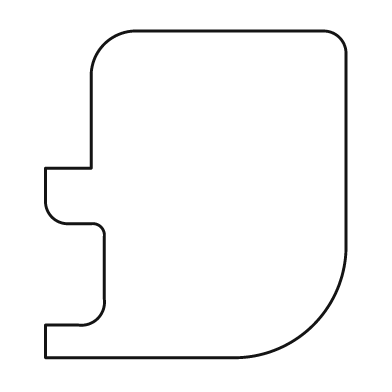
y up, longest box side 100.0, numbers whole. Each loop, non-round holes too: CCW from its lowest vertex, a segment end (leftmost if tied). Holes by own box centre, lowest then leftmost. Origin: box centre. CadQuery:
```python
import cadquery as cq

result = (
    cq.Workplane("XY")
    .moveTo(-46.0, -50.0)
    .lineTo(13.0, -50.0)
    .threePointArc((36.0, -40.0), (46.0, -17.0))
    .lineTo(46.0, 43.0)
    .threePointArc((44.0, 48.0), (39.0, 50.0))
    .lineTo(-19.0, 50.0)
    .threePointArc((-28.0, 46.0), (-32.0, 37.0))
    .lineTo(-32.0, 8.0)
    .lineTo(-46.0, 8.0)
    .lineTo(-46.0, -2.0)
    .threePointArc((-44.0, -7.0), (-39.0, -9.0))
    .lineTo(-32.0, -9.0)
    .threePointArc((-29.0, -10.0), (-28.0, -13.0))
    .lineTo(-28.0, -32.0)
    .threePointArc((-30.0, -38.0), (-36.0, -40.0))
    .lineTo(-46.0, -40.0)
    .close()
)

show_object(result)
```